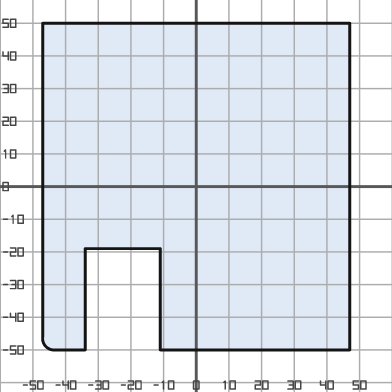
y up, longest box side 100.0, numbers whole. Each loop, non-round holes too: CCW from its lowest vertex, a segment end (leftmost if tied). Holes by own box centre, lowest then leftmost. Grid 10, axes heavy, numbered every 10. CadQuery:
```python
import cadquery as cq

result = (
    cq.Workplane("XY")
    .moveTo(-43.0, -50.0)
    .lineTo(-34.0, -50.0)
    .lineTo(-34.0, -19.0)
    .lineTo(-11.0, -19.0)
    .lineTo(-11.0, -50.0)
    .lineTo(47.0, -50.0)
    .lineTo(47.0, 50.0)
    .lineTo(-47.0, 50.0)
    .lineTo(-47.0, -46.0)
    .threePointArc((-46.0, -49.0), (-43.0, -50.0))
    .close()
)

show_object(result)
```